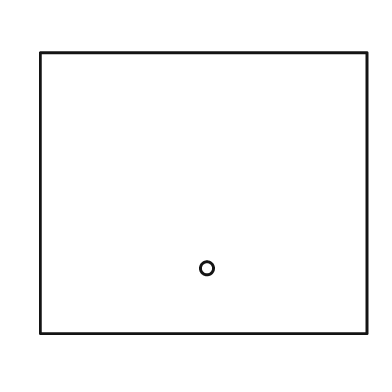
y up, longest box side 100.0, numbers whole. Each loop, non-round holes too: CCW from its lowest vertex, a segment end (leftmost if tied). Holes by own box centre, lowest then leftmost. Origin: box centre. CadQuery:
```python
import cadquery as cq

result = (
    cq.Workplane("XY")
    .moveTo(-50.0, -43.0)
    .lineTo(50.0, -43.0)
    .lineTo(50.0, 43.0)
    .lineTo(-50.0, 43.0)
    .close()
    .moveTo(1.0, -23.0)
    .circle(2.0)
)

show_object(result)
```